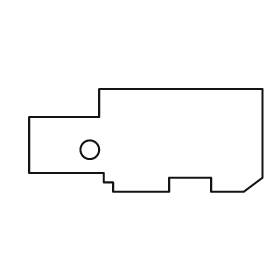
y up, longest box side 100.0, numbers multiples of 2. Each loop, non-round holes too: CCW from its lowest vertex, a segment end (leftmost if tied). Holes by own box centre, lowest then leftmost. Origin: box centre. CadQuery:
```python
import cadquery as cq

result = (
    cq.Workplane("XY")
    .moveTo(-14.0, -22.0)
    .lineTo(10.0, -22.0)
    .lineTo(10.0, -16.0)
    .lineTo(28.0, -16.0)
    .lineTo(28.0, -22.0)
    .lineTo(42.0, -22.0)
    .lineTo(50.0, -16.0)
    .lineTo(50.0, 22.0)
    .lineTo(-20.0, 22.0)
    .lineTo(-20.0, 10.0)
    .lineTo(-50.0, 10.0)
    .lineTo(-50.0, -14.0)
    .lineTo(-18.0, -14.0)
    .lineTo(-18.0, -18.0)
    .lineTo(-14.0, -18.0)
    .close()
    .moveTo(-24.0, -4.0)
    .circle(4.0)
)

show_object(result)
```